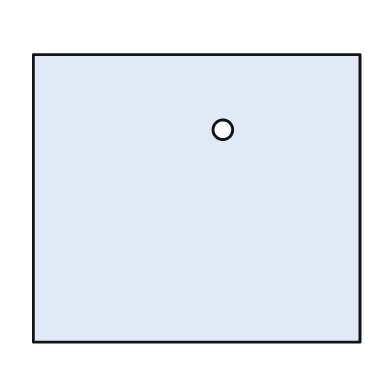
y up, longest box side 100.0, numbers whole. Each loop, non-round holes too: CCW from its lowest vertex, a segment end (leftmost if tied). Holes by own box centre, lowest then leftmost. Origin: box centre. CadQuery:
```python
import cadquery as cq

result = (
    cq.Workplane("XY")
    .moveTo(-50.0, -44.0)
    .lineTo(50.0, -44.0)
    .lineTo(50.0, 44.0)
    .lineTo(-50.0, 44.0)
    .close()
    .moveTo(8.0, 21.0)
    .circle(3.0)
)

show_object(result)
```